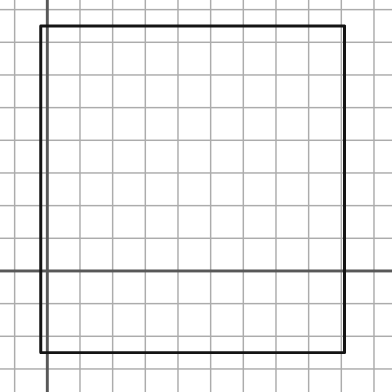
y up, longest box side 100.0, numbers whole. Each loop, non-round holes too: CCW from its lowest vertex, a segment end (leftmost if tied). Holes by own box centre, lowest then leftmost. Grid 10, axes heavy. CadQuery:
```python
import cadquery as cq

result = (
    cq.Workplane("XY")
    .moveTo(-2.0, -25.0)
    .lineTo(91.0, -25.0)
    .lineTo(91.0, 75.0)
    .lineTo(-2.0, 75.0)
    .close()
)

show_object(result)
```